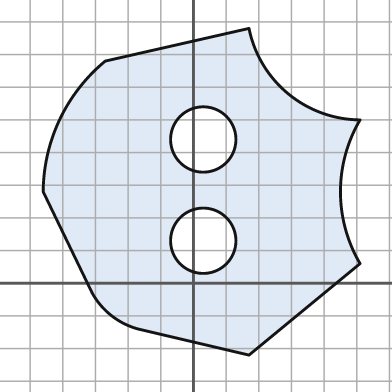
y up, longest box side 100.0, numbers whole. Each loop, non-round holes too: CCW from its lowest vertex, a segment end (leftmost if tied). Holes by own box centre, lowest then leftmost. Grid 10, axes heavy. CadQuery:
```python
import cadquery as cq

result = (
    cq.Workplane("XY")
    .moveTo(17.0, -22.0)
    .lineTo(51.0, 6.0)
    .threePointArc((45.0, 28.0), (51.0, 50.0))
    .threePointArc((29.0, 58.0), (17.0, 78.0))
    .lineTo(-27.0, 68.0)
    .threePointArc((-41.0, 50.0), (-46.0, 28.0))
    .lineTo(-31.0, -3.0)
    .threePointArc((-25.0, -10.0), (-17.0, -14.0))
    .close()
    .moveTo(3.0, 13.0)
    .circle(10.0)
    .moveTo(3.0, 44.0)
    .circle(10.0)
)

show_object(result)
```